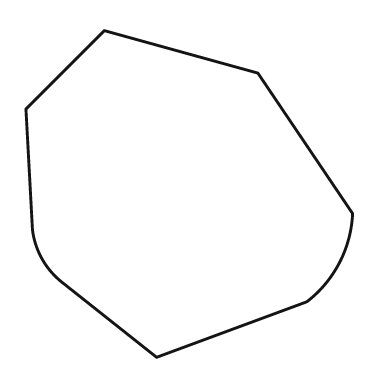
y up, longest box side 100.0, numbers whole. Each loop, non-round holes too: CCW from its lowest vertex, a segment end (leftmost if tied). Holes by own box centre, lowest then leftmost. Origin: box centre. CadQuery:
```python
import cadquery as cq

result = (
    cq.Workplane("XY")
    .moveTo(-10.0, -50.0)
    .lineTo(36.0, -33.0)
    .threePointArc((46.0, -21.0), (50.0, -6.0))
    .lineTo(21.0, 37.0)
    .lineTo(-26.0, 50.0)
    .lineTo(-50.0, 26.0)
    .lineTo(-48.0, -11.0)
    .threePointArc((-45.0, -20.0), (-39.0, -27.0))
    .close()
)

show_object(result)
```